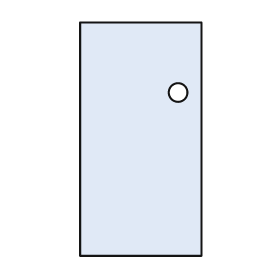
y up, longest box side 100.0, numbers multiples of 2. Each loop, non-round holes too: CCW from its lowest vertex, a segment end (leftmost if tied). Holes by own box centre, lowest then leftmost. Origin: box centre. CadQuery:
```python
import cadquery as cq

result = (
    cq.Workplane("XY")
    .moveTo(-26.0, -50.0)
    .lineTo(26.0, -50.0)
    .lineTo(26.0, 50.0)
    .lineTo(-26.0, 50.0)
    .close()
    .moveTo(16.0, 20.0)
    .circle(4.0)
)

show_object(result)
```